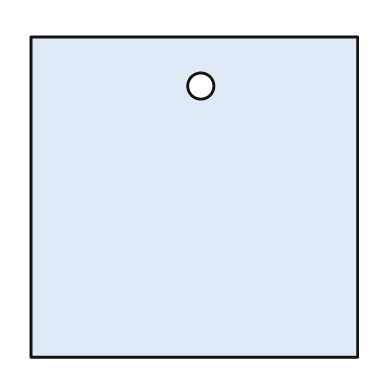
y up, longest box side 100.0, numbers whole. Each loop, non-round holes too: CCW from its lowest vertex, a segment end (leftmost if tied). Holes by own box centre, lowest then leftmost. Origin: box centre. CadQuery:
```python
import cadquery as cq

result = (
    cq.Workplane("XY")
    .moveTo(-50.0, -49.0)
    .lineTo(50.0, -49.0)
    .lineTo(50.0, 49.0)
    .lineTo(-50.0, 49.0)
    .close()
    .moveTo(2.0, 34.0)
    .circle(4.0)
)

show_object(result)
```